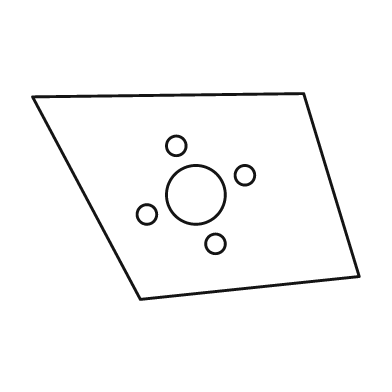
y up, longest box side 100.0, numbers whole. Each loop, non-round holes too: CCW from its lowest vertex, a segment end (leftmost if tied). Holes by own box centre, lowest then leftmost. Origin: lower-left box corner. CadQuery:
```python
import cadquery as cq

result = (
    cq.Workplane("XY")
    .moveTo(33.0, 0.0)
    .lineTo(100.0, 7.0)
    .lineTo(83.0, 63.0)
    .lineTo(0.0, 62.0)
    .close()
    .moveTo(56.0, 17.0)
    .circle(3.0)
    .moveTo(35.0, 26.0)
    .circle(3.0)
    .moveTo(50.0, 32.0)
    .circle(9.0)
    .moveTo(65.0, 38.0)
    .circle(3.0)
    .moveTo(44.0, 47.0)
    .circle(3.0)
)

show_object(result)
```